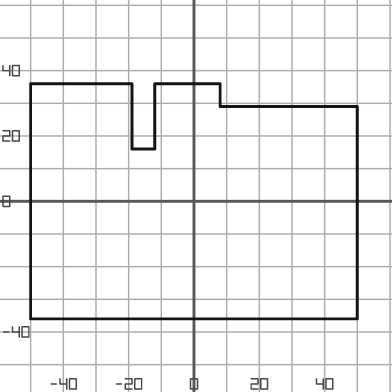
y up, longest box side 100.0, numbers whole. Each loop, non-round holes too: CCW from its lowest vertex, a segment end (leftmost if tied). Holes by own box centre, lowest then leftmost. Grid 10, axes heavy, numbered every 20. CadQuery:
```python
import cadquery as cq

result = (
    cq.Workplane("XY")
    .moveTo(-50.0, -36.0)
    .lineTo(50.0, -36.0)
    .lineTo(50.0, 29.0)
    .lineTo(8.0, 29.0)
    .lineTo(8.0, 36.0)
    .lineTo(-12.0, 36.0)
    .lineTo(-12.0, 16.0)
    .lineTo(-19.0, 16.0)
    .lineTo(-19.0, 36.0)
    .lineTo(-50.0, 36.0)
    .close()
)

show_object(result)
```